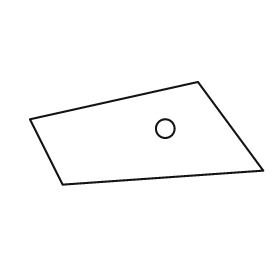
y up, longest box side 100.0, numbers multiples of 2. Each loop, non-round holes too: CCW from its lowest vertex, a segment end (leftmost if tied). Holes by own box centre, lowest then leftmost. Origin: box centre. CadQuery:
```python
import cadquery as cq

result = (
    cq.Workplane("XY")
    .moveTo(-36.0, -22.0)
    .lineTo(50.0, -16.0)
    .lineTo(22.0, 22.0)
    .lineTo(-50.0, 6.0)
    .close()
    .moveTo(8.0, 2.0)
    .circle(4.0)
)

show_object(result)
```